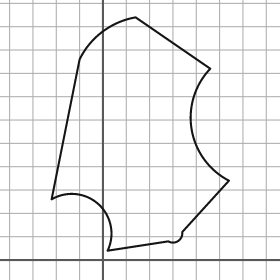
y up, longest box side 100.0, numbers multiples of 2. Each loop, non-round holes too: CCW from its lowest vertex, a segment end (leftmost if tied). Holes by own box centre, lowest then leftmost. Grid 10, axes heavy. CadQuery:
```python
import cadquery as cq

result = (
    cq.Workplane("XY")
    .moveTo(2.0, 4.0)
    .lineTo(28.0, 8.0)
    .threePointArc((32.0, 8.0), (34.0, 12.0))
    .lineTo(54.0, 34.0)
    .threePointArc((38.0, 56.0), (46.0, 82.0))
    .lineTo(14.0, 104.0)
    .threePointArc((0.0, 98.0), (-10.0, 86.0))
    .lineTo(-22.0, 26.0)
    .threePointArc((-2.0, 24.0), (2.0, 4.0))
    .close()
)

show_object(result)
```